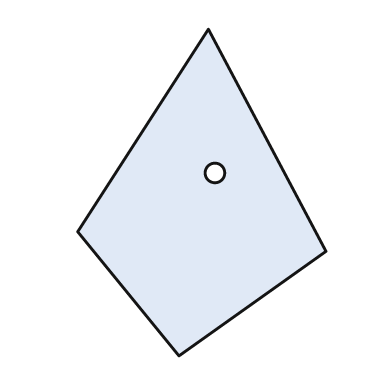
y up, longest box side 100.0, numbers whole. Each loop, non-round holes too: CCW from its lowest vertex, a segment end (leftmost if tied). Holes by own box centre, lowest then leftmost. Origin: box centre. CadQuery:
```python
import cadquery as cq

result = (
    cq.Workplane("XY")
    .moveTo(-7.0, -50.0)
    .lineTo(38.0, -18.0)
    .lineTo(2.0, 50.0)
    .lineTo(-38.0, -12.0)
    .close()
    .moveTo(4.0, 6.0)
    .circle(3.0)
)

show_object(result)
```